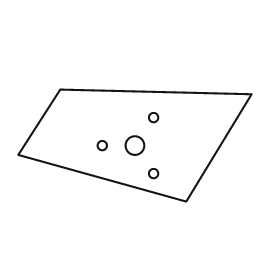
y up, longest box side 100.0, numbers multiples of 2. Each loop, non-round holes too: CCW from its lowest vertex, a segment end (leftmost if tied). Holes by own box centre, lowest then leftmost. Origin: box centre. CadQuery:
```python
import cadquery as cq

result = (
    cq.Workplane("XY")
    .moveTo(22.0, -24.0)
    .lineTo(50.0, 22.0)
    .lineTo(-32.0, 24.0)
    .lineTo(-50.0, -4.0)
    .close()
    .moveTo(8.0, -12.0)
    .circle(2.0)
    .moveTo(-14.0, 0.0)
    .circle(2.0)
    .moveTo(0.0, 0.0)
    .circle(4.0)
    .moveTo(8.0, 12.0)
    .circle(2.0)
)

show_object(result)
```